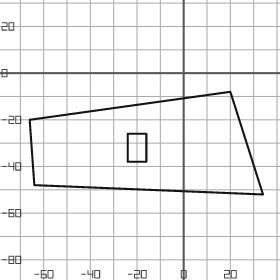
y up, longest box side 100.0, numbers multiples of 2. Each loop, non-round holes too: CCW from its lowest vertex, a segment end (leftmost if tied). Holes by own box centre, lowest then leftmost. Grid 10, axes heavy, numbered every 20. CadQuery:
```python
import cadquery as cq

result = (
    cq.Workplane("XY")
    .moveTo(34.0, -52.0)
    .lineTo(20.0, -8.0)
    .lineTo(-66.0, -20.0)
    .lineTo(-64.0, -48.0)
    .close()
    .moveTo(-24.0, -38.0)
    .lineTo(-16.0, -38.0)
    .lineTo(-16.0, -26.0)
    .lineTo(-24.0, -26.0)
    .close()
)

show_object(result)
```